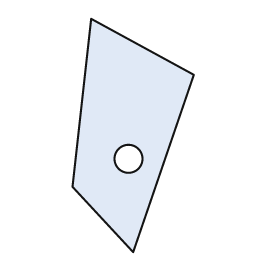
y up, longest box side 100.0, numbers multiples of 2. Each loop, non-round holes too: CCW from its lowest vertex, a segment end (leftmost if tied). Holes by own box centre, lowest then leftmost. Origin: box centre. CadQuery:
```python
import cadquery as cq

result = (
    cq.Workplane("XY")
    .moveTo(0.0, -50.0)
    .lineTo(26.0, 26.0)
    .lineTo(-18.0, 50.0)
    .lineTo(-26.0, -22.0)
    .close()
    .moveTo(-2.0, -10.0)
    .circle(6.0)
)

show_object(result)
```